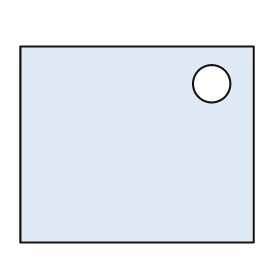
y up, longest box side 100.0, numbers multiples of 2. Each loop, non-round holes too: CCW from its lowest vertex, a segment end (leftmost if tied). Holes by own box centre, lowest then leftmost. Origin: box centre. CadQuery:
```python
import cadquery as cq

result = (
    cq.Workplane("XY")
    .moveTo(-50.0, -42.0)
    .lineTo(50.0, -42.0)
    .lineTo(50.0, 42.0)
    .lineTo(-50.0, 42.0)
    .close()
    .moveTo(32.0, 26.0)
    .circle(8.0)
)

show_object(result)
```